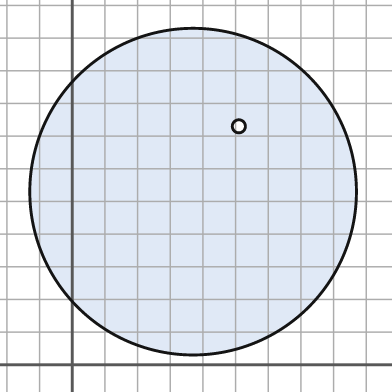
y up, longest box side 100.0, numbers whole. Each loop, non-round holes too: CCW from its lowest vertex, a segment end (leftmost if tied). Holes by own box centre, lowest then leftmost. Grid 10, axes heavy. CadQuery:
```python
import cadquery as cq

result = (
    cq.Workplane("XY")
    .moveTo(37.0, 53.0)
    .circle(50.0)
    .moveTo(51.0, 73.0)
    .circle(2.0)
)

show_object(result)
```